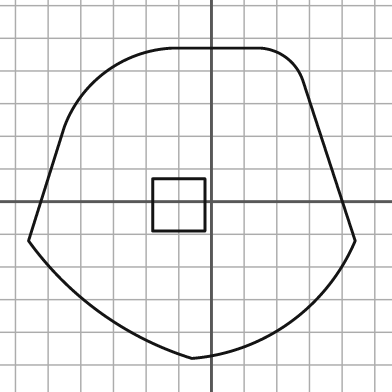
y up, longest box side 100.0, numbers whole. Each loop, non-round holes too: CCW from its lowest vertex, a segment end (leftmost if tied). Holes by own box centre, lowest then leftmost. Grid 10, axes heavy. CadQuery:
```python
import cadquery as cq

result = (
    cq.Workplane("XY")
    .moveTo(-6.0, -48.0)
    .threePointArc((24.0, -37.0), (44.0, -12.0))
    .lineTo(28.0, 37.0)
    .threePointArc((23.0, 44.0), (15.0, 47.0))
    .lineTo(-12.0, 47.0)
    .threePointArc((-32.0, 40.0), (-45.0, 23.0))
    .lineTo(-56.0, -12.0)
    .threePointArc((-34.0, -34.0), (-6.0, -48.0))
    .close()
    .moveTo(-18.0, -9.0)
    .lineTo(-2.0, -9.0)
    .lineTo(-2.0, 7.0)
    .lineTo(-18.0, 7.0)
    .close()
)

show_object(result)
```